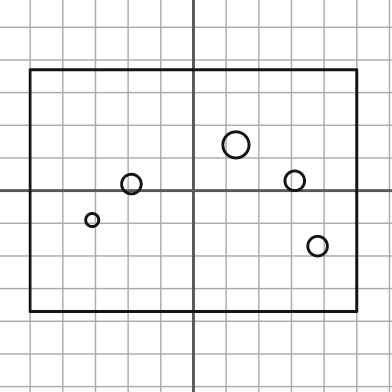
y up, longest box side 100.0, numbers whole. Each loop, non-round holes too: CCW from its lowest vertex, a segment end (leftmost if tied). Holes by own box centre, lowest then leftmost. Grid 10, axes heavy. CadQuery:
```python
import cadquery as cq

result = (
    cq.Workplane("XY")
    .moveTo(-50.0, -37.0)
    .lineTo(50.0, -37.0)
    .lineTo(50.0, 37.0)
    .lineTo(-50.0, 37.0)
    .close()
    .moveTo(38.0, -17.0)
    .circle(3.0)
    .moveTo(-31.0, -9.0)
    .circle(2.0)
    .moveTo(-19.0, 2.0)
    .circle(3.0)
    .moveTo(31.0, 3.0)
    .circle(3.0)
    .moveTo(13.0, 14.0)
    .circle(4.0)
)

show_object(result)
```